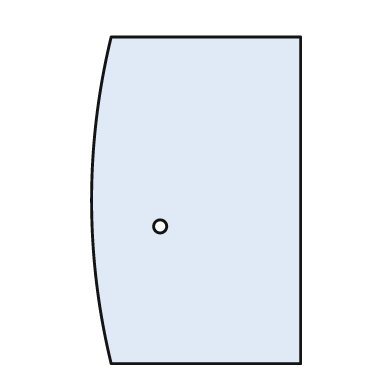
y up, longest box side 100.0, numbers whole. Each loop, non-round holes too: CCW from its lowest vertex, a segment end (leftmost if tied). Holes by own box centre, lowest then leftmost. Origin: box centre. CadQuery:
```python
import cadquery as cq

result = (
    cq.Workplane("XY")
    .moveTo(-26.0, -50.0)
    .lineTo(32.0, -50.0)
    .lineTo(32.0, 50.0)
    .lineTo(-26.0, 50.0)
    .threePointArc((-32.0, 0.0), (-26.0, -50.0))
    .close()
    .moveTo(-11.0, -8.0)
    .circle(2.0)
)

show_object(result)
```